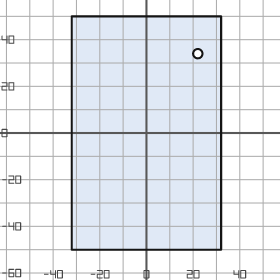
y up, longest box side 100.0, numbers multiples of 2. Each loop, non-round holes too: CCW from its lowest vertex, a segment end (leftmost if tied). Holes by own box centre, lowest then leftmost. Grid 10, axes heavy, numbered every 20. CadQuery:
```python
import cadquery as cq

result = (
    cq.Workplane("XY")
    .moveTo(-32.0, -50.0)
    .lineTo(32.0, -50.0)
    .lineTo(32.0, 50.0)
    .lineTo(-32.0, 50.0)
    .close()
    .moveTo(22.0, 34.0)
    .circle(2.0)
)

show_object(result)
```